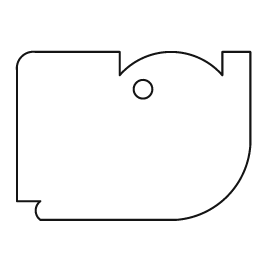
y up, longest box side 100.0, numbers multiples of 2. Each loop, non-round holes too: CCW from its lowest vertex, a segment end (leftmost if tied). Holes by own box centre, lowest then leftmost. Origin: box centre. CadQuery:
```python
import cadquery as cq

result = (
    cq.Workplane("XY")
    .moveTo(-40.0, -36.0)
    .lineTo(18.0, -36.0)
    .threePointArc((40.0, -26.0), (50.0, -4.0))
    .lineTo(50.0, 36.0)
    .lineTo(38.0, 36.0)
    .lineTo(38.0, 26.0)
    .threePointArc((16.0, 36.0), (-6.0, 26.0))
    .lineTo(-6.0, 36.0)
    .lineTo(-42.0, 36.0)
    .threePointArc((-48.0, 34.0), (-50.0, 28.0))
    .lineTo(-50.0, -28.0)
    .lineTo(-40.0, -28.0)
    .threePointArc((-42.0, -32.0), (-40.0, -36.0))
    .close()
    .moveTo(4.0, 20.0)
    .circle(4.0)
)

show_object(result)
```